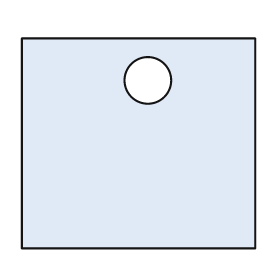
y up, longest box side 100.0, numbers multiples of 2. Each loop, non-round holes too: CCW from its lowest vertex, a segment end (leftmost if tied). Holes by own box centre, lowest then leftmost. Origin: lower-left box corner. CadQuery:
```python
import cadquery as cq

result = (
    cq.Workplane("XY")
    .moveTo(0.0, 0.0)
    .lineTo(100.0, 0.0)
    .lineTo(100.0, 90.0)
    .lineTo(0.0, 90.0)
    .close()
    .moveTo(54.0, 72.0)
    .circle(10.0)
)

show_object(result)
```